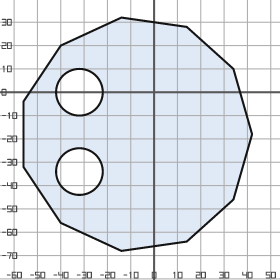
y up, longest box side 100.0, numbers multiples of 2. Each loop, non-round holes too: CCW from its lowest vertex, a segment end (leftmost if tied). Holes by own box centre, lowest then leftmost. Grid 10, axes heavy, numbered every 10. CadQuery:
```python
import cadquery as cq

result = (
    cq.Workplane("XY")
    .moveTo(-14.0, -68.0)
    .lineTo(14.0, -64.0)
    .lineTo(34.0, -46.0)
    .lineTo(42.0, -18.0)
    .lineTo(34.0, 10.0)
    .lineTo(14.0, 28.0)
    .lineTo(-14.0, 32.0)
    .lineTo(-40.0, 20.0)
    .lineTo(-56.0, -4.0)
    .lineTo(-56.0, -32.0)
    .lineTo(-40.0, -56.0)
    .close()
    .moveTo(-32.0, -34.0)
    .circle(10.0)
    .moveTo(-32.0, 0.0)
    .circle(10.0)
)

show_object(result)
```